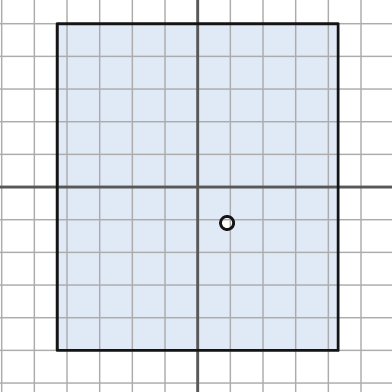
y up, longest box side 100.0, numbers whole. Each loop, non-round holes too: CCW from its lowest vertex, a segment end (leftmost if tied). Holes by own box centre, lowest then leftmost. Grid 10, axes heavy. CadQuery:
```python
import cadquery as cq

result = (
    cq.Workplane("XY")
    .moveTo(-43.0, -50.0)
    .lineTo(43.0, -50.0)
    .lineTo(43.0, 50.0)
    .lineTo(-43.0, 50.0)
    .close()
    .moveTo(9.0, -11.0)
    .circle(2.0)
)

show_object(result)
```